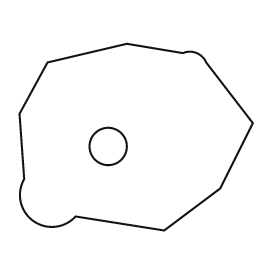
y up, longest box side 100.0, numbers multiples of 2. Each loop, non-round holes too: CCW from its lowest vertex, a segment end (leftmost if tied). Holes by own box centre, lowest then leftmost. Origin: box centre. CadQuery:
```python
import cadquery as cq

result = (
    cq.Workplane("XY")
    .moveTo(12.0, -40.0)
    .lineTo(36.0, -22.0)
    .lineTo(50.0, 6.0)
    .lineTo(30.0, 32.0)
    .threePointArc((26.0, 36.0), (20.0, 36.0))
    .lineTo(-4.0, 40.0)
    .lineTo(-38.0, 32.0)
    .lineTo(-50.0, 10.0)
    .lineTo(-48.0, -18.0)
    .threePointArc((-44.0, -36.0), (-26.0, -34.0))
    .close()
    .moveTo(-12.0, -4.0)
    .circle(8.0)
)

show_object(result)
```